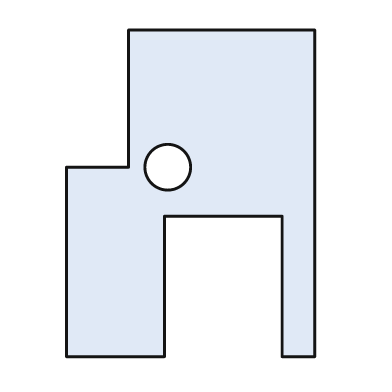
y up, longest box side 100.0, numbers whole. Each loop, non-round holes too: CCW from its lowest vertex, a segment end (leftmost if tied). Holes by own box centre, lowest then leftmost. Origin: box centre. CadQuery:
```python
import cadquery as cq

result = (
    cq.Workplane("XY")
    .moveTo(-38.0, -50.0)
    .lineTo(-8.0, -50.0)
    .lineTo(-8.0, -7.0)
    .lineTo(28.0, -7.0)
    .lineTo(28.0, -50.0)
    .lineTo(38.0, -50.0)
    .lineTo(38.0, 50.0)
    .lineTo(-19.0, 50.0)
    .lineTo(-19.0, 8.0)
    .lineTo(-38.0, 8.0)
    .close()
    .moveTo(-7.0, 8.0)
    .circle(7.0)
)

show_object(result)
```